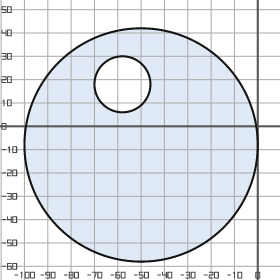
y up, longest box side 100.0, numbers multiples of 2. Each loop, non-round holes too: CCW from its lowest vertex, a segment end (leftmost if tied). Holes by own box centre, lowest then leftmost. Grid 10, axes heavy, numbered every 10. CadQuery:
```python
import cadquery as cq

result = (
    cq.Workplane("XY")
    .moveTo(-50.0, -8.0)
    .circle(50.0)
    .moveTo(-58.0, 18.0)
    .circle(12.0)
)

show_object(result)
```